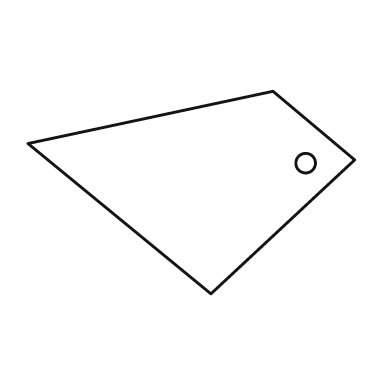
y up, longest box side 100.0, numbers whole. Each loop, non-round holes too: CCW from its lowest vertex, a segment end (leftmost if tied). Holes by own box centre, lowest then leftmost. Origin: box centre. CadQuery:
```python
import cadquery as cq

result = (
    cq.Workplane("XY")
    .moveTo(6.0, -31.0)
    .lineTo(50.0, 10.0)
    .lineTo(25.0, 31.0)
    .lineTo(-50.0, 15.0)
    .close()
    .moveTo(35.0, 9.0)
    .circle(3.0)
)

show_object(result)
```